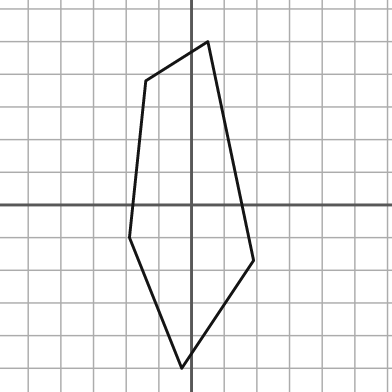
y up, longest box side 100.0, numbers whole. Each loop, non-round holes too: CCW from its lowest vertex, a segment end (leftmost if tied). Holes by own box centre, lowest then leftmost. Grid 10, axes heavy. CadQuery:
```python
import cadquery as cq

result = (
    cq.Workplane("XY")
    .moveTo(-3.0, -50.0)
    .lineTo(19.0, -17.0)
    .lineTo(5.0, 50.0)
    .lineTo(-14.0, 38.0)
    .lineTo(-19.0, -10.0)
    .close()
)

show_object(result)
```